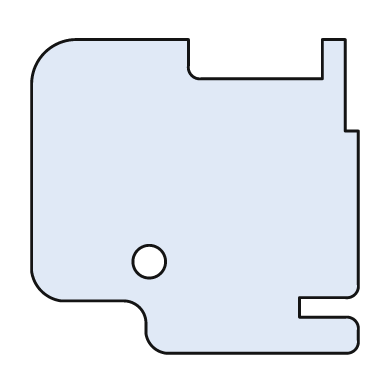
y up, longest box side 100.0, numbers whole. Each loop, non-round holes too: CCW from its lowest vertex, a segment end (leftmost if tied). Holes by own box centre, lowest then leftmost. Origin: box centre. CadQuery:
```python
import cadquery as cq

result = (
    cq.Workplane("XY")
    .moveTo(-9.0, -48.0)
    .lineTo(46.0, -48.0)
    .threePointArc((49.0, -47.0), (50.0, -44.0))
    .lineTo(50.0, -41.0)
    .threePointArc((49.0, -38.0), (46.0, -37.0))
    .lineTo(32.0, -37.0)
    .lineTo(32.0, -31.0)
    .lineTo(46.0, -31.0)
    .threePointArc((49.0, -30.0), (50.0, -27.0))
    .lineTo(50.0, 20.0)
    .lineTo(46.0, 20.0)
    .lineTo(46.0, 48.0)
    .lineTo(39.0, 48.0)
    .lineTo(39.0, 36.0)
    .lineTo(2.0, 36.0)
    .threePointArc((-1.0, 37.0), (-2.0, 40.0))
    .lineTo(-2.0, 48.0)
    .lineTo(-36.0, 48.0)
    .threePointArc((-46.0, 44.0), (-50.0, 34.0))
    .lineTo(-50.0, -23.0)
    .threePointArc((-47.0, -29.0), (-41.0, -32.0))
    .lineTo(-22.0, -32.0)
    .threePointArc((-17.0, -34.0), (-15.0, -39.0))
    .lineTo(-15.0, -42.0)
    .threePointArc((-13.0, -46.0), (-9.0, -48.0))
    .close()
    .moveTo(-14.0, -20.0)
    .circle(5.0)
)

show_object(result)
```